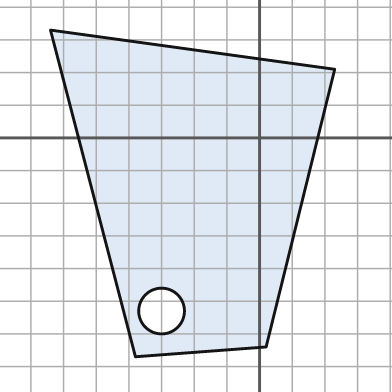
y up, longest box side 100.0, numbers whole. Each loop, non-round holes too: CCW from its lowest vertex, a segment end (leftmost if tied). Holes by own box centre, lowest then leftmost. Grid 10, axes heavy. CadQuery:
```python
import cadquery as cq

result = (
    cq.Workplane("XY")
    .moveTo(-38.0, -67.0)
    .lineTo(2.0, -64.0)
    .lineTo(23.0, 21.0)
    .lineTo(-64.0, 33.0)
    .close()
    .moveTo(-30.0, -53.0)
    .circle(7.0)
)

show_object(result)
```